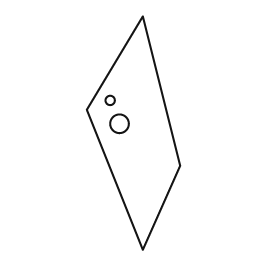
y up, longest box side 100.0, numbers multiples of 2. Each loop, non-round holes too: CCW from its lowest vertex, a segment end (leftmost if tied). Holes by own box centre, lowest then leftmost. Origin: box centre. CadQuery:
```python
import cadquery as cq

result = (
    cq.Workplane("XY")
    .moveTo(4.0, -50.0)
    .lineTo(20.0, -14.0)
    .lineTo(4.0, 50.0)
    .lineTo(-20.0, 10.0)
    .close()
    .moveTo(-6.0, 4.0)
    .circle(4.0)
    .moveTo(-10.0, 14.0)
    .circle(2.0)
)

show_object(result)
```